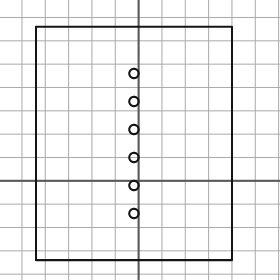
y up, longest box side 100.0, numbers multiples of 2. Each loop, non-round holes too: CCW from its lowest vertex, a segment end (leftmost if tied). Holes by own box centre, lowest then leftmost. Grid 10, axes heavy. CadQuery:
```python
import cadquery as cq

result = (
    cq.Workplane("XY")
    .moveTo(-44.0, -34.0)
    .lineTo(40.0, -34.0)
    .lineTo(40.0, 66.0)
    .lineTo(-44.0, 66.0)
    .close()
    .moveTo(-2.0, -14.0)
    .circle(2.0)
    .moveTo(-2.0, -2.0)
    .circle(2.0)
    .moveTo(-2.0, 10.0)
    .circle(2.0)
    .moveTo(-2.0, 22.0)
    .circle(2.0)
    .moveTo(-2.0, 34.0)
    .circle(2.0)
    .moveTo(-2.0, 46.0)
    .circle(2.0)
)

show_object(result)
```